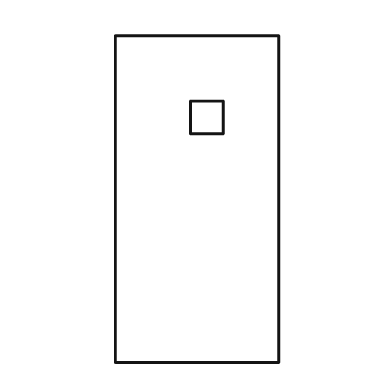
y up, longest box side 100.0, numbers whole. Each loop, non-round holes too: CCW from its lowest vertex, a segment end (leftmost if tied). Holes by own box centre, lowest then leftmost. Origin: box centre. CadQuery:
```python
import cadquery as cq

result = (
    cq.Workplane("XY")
    .moveTo(-25.0, -50.0)
    .lineTo(25.0, -50.0)
    .lineTo(25.0, 50.0)
    .lineTo(-25.0, 50.0)
    .close()
    .moveTo(-2.0, 20.0)
    .lineTo(8.0, 20.0)
    .lineTo(8.0, 30.0)
    .lineTo(-2.0, 30.0)
    .close()
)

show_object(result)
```